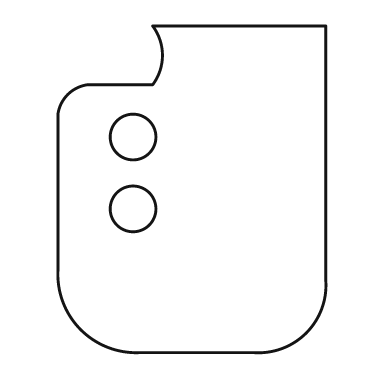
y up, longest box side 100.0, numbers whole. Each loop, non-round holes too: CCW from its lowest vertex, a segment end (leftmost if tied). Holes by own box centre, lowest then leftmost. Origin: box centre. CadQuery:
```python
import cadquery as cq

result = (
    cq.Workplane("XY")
    .moveTo(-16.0, -50.0)
    .lineTo(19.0, -50.0)
    .threePointArc((35.0, -44.0), (41.0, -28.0))
    .lineTo(41.0, 50.0)
    .lineTo(-12.0, 50.0)
    .threePointArc((-9.0, 41.0), (-12.0, 32.0))
    .lineTo(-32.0, 32.0)
    .threePointArc((-38.0, 29.0), (-41.0, 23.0))
    .lineTo(-41.0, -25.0)
    .threePointArc((-34.0, -43.0), (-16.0, -50.0))
    .close()
    .moveTo(-18.0, -6.0)
    .circle(7.0)
    .moveTo(-18.0, 16.0)
    .circle(7.0)
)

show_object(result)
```